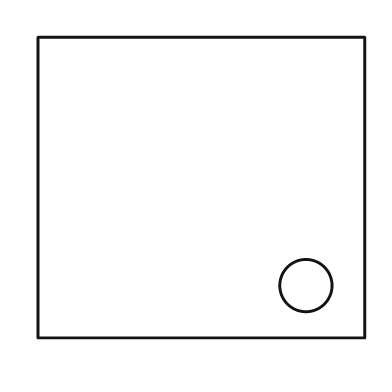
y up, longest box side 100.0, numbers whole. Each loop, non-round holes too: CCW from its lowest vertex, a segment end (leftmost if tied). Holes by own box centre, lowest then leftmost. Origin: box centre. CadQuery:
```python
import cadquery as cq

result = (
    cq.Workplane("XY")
    .moveTo(-50.0, -46.0)
    .lineTo(50.0, -46.0)
    .lineTo(50.0, 46.0)
    .lineTo(-50.0, 46.0)
    .close()
    .moveTo(32.0, -30.0)
    .circle(8.0)
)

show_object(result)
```